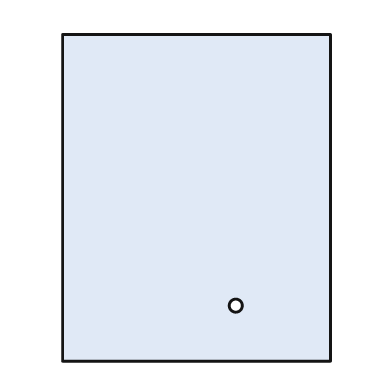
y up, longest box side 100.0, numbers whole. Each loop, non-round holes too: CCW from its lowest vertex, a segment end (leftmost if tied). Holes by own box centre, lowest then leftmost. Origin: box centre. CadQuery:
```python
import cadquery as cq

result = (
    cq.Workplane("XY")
    .moveTo(-41.0, -50.0)
    .lineTo(41.0, -50.0)
    .lineTo(41.0, 50.0)
    .lineTo(-41.0, 50.0)
    .close()
    .moveTo(12.0, -33.0)
    .circle(2.0)
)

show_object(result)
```